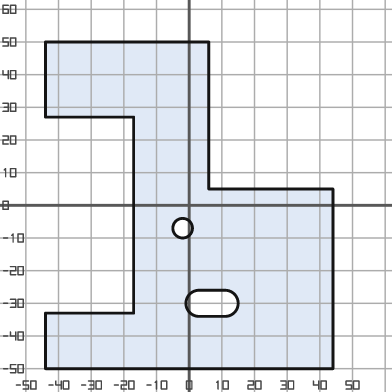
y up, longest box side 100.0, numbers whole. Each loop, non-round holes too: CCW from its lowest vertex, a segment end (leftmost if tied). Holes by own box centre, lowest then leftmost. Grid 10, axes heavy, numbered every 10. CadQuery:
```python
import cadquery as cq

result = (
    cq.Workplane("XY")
    .moveTo(-44.0, -50.0)
    .lineTo(44.0, -50.0)
    .lineTo(44.0, 5.0)
    .lineTo(6.0, 5.0)
    .lineTo(6.0, 50.0)
    .lineTo(-44.0, 50.0)
    .lineTo(-44.0, 27.0)
    .lineTo(-17.0, 27.0)
    .lineTo(-17.0, -33.0)
    .lineTo(-44.0, -33.0)
    .close()
    .moveTo(3.0, -34.0)
    .lineTo(11.0, -34.0)
    .threePointArc((15.0, -30.0), (11.0, -26.0))
    .lineTo(3.0, -26.0)
    .threePointArc((-1.0, -30.0), (3.0, -34.0))
    .close()
    .moveTo(-2.0, -7.0)
    .circle(3.0)
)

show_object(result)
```